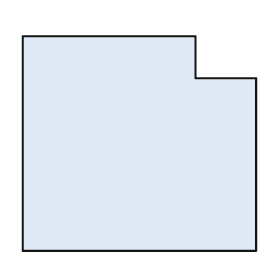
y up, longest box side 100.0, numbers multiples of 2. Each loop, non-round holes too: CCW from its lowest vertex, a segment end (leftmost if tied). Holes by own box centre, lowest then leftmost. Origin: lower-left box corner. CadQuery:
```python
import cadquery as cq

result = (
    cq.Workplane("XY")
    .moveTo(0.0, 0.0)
    .lineTo(100.0, 0.0)
    .lineTo(100.0, 74.0)
    .lineTo(74.0, 74.0)
    .lineTo(74.0, 92.0)
    .lineTo(0.0, 92.0)
    .close()
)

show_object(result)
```